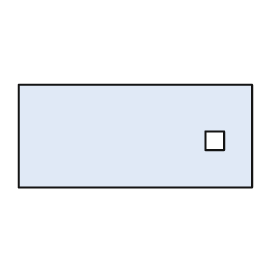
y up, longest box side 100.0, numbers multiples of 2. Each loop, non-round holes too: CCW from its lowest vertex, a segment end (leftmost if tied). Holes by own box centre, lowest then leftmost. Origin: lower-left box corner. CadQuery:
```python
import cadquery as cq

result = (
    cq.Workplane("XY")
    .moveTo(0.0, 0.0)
    .lineTo(100.0, 0.0)
    .lineTo(100.0, 44.0)
    .lineTo(0.0, 44.0)
    .close()
    .moveTo(80.0, 16.0)
    .lineTo(88.0, 16.0)
    .lineTo(88.0, 24.0)
    .lineTo(80.0, 24.0)
    .close()
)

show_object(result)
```